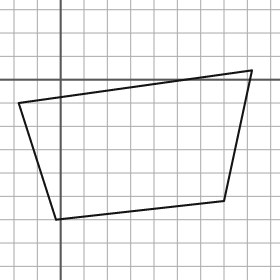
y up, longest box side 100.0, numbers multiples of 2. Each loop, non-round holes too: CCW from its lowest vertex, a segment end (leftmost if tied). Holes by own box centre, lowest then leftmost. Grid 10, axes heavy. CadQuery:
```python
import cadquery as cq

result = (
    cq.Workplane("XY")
    .moveTo(-2.0, -60.0)
    .lineTo(70.0, -52.0)
    .lineTo(82.0, 4.0)
    .lineTo(-18.0, -10.0)
    .close()
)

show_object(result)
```